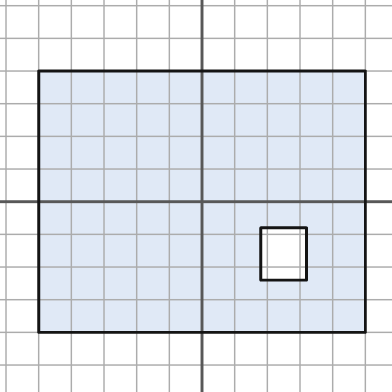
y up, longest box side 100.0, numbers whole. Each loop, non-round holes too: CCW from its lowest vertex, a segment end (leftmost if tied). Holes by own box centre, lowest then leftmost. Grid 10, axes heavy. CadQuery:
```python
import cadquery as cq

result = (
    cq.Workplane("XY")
    .moveTo(-50.0, -40.0)
    .lineTo(50.0, -40.0)
    .lineTo(50.0, 40.0)
    .lineTo(-50.0, 40.0)
    .close()
    .moveTo(18.0, -24.0)
    .lineTo(32.0, -24.0)
    .lineTo(32.0, -8.0)
    .lineTo(18.0, -8.0)
    .close()
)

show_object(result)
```